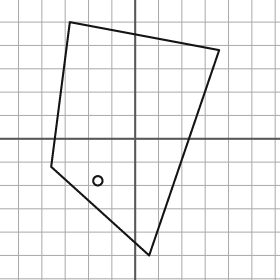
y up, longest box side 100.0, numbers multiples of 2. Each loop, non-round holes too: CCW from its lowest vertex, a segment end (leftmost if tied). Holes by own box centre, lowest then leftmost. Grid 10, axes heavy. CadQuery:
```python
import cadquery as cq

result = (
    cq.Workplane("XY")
    .moveTo(6.0, -50.0)
    .lineTo(36.0, 38.0)
    .lineTo(-28.0, 50.0)
    .lineTo(-36.0, -12.0)
    .close()
    .moveTo(-16.0, -18.0)
    .circle(2.0)
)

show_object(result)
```